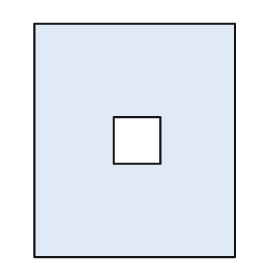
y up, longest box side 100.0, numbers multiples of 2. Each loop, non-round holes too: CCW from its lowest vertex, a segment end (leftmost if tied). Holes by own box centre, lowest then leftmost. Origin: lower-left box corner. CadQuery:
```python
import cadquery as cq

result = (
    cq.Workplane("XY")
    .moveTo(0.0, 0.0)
    .lineTo(86.0, 0.0)
    .lineTo(86.0, 100.0)
    .lineTo(0.0, 100.0)
    .close()
    .moveTo(34.0, 40.0)
    .lineTo(54.0, 40.0)
    .lineTo(54.0, 60.0)
    .lineTo(34.0, 60.0)
    .close()
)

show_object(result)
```